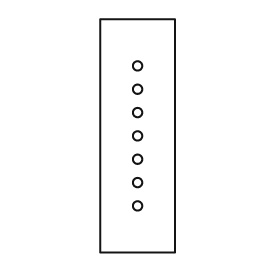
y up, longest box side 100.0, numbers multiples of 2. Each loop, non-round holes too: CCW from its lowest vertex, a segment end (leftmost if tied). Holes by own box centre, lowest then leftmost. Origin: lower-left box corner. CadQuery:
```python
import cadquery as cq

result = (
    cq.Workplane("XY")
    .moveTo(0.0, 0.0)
    .lineTo(32.0, 0.0)
    .lineTo(32.0, 100.0)
    .lineTo(0.0, 100.0)
    .close()
    .moveTo(16.0, 20.0)
    .circle(2.0)
    .moveTo(16.0, 30.0)
    .circle(2.0)
    .moveTo(16.0, 40.0)
    .circle(2.0)
    .moveTo(16.0, 50.0)
    .circle(2.0)
    .moveTo(16.0, 60.0)
    .circle(2.0)
    .moveTo(16.0, 70.0)
    .circle(2.0)
    .moveTo(16.0, 80.0)
    .circle(2.0)
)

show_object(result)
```